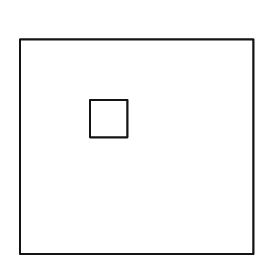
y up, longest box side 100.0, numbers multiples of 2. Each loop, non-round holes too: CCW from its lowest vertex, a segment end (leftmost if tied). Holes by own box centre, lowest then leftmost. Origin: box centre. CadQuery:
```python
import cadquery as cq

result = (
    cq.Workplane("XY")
    .moveTo(-50.0, -46.0)
    .lineTo(50.0, -46.0)
    .lineTo(50.0, 46.0)
    .lineTo(-50.0, 46.0)
    .close()
    .moveTo(-20.0, 4.0)
    .lineTo(-4.0, 4.0)
    .lineTo(-4.0, 20.0)
    .lineTo(-20.0, 20.0)
    .close()
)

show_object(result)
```